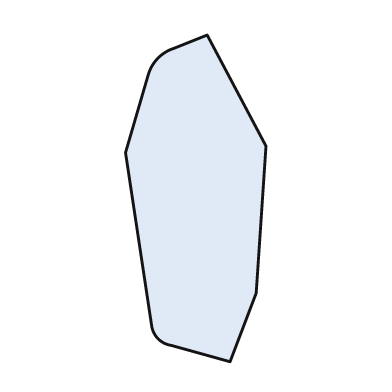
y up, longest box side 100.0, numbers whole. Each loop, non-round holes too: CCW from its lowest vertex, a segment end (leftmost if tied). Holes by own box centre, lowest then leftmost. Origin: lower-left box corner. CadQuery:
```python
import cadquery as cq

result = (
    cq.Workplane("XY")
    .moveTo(32.0, 0.0)
    .lineTo(40.0, 21.0)
    .lineTo(43.0, 66.0)
    .lineTo(25.0, 100.0)
    .lineTo(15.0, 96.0)
    .threePointArc((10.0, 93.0), (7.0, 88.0))
    .lineTo(0.0, 64.0)
    .lineTo(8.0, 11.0)
    .threePointArc((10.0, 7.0), (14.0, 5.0))
    .close()
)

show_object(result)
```